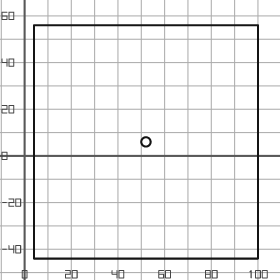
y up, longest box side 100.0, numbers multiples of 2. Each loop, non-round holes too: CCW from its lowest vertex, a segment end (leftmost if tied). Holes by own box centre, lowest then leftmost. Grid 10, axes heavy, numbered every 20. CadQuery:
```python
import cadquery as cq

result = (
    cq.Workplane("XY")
    .moveTo(4.0, -44.0)
    .lineTo(100.0, -44.0)
    .lineTo(100.0, 56.0)
    .lineTo(4.0, 56.0)
    .close()
    .moveTo(52.0, 6.0)
    .circle(2.0)
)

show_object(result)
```